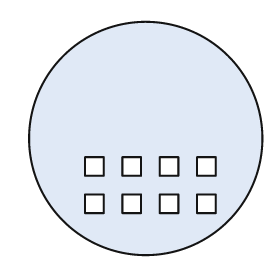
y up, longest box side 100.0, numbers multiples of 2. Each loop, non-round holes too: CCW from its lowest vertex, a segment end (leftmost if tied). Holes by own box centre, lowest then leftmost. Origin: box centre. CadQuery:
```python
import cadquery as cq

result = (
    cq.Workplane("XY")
    .moveTo(0.0, 0.0)
    .circle(50.0)
    .moveTo(-26.0, -32.0)
    .lineTo(-18.0, -32.0)
    .lineTo(-18.0, -24.0)
    .lineTo(-26.0, -24.0)
    .close()
    .moveTo(-10.0, -32.0)
    .lineTo(-2.0, -32.0)
    .lineTo(-2.0, -24.0)
    .lineTo(-10.0, -24.0)
    .close()
    .moveTo(6.0, -32.0)
    .lineTo(14.0, -32.0)
    .lineTo(14.0, -24.0)
    .lineTo(6.0, -24.0)
    .close()
    .moveTo(22.0, -32.0)
    .lineTo(30.0, -32.0)
    .lineTo(30.0, -24.0)
    .lineTo(22.0, -24.0)
    .close()
    .moveTo(-26.0, -16.0)
    .lineTo(-18.0, -16.0)
    .lineTo(-18.0, -8.0)
    .lineTo(-26.0, -8.0)
    .close()
    .moveTo(-10.0, -16.0)
    .lineTo(-2.0, -16.0)
    .lineTo(-2.0, -8.0)
    .lineTo(-10.0, -8.0)
    .close()
    .moveTo(6.0, -16.0)
    .lineTo(14.0, -16.0)
    .lineTo(14.0, -8.0)
    .lineTo(6.0, -8.0)
    .close()
    .moveTo(22.0, -16.0)
    .lineTo(30.0, -16.0)
    .lineTo(30.0, -8.0)
    .lineTo(22.0, -8.0)
    .close()
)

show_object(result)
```